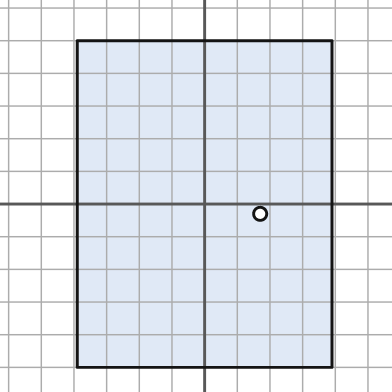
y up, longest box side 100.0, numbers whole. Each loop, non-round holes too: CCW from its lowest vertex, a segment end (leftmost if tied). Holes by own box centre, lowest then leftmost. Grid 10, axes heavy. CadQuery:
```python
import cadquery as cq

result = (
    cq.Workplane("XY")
    .moveTo(-39.0, -50.0)
    .lineTo(39.0, -50.0)
    .lineTo(39.0, 50.0)
    .lineTo(-39.0, 50.0)
    .close()
    .moveTo(17.0, -3.0)
    .circle(2.0)
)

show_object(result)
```